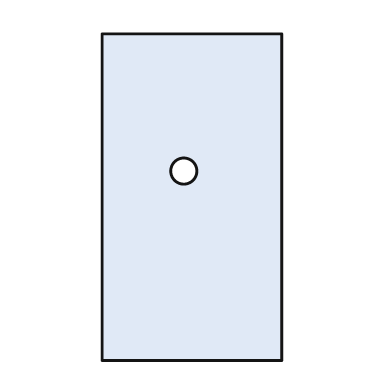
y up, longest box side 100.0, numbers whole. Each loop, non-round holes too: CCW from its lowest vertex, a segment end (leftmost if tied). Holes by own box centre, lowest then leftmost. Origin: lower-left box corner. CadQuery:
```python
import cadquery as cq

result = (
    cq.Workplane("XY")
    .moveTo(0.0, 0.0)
    .lineTo(55.0, 0.0)
    .lineTo(55.0, 100.0)
    .lineTo(0.0, 100.0)
    .close()
    .moveTo(25.0, 58.0)
    .circle(4.0)
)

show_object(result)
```